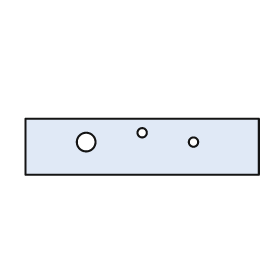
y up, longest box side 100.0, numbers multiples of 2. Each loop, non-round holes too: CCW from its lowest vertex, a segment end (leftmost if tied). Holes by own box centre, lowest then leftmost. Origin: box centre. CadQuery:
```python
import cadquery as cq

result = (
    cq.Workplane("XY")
    .moveTo(-50.0, -12.0)
    .lineTo(50.0, -12.0)
    .lineTo(50.0, 12.0)
    .lineTo(-50.0, 12.0)
    .close()
    .moveTo(-24.0, 2.0)
    .circle(4.0)
    .moveTo(22.0, 2.0)
    .circle(2.0)
    .moveTo(0.0, 6.0)
    .circle(2.0)
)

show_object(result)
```